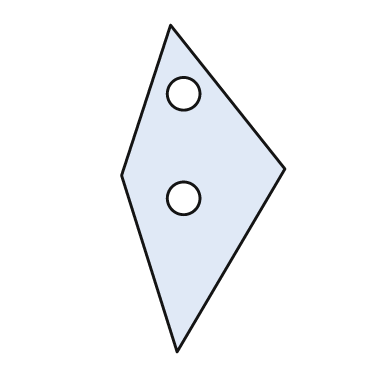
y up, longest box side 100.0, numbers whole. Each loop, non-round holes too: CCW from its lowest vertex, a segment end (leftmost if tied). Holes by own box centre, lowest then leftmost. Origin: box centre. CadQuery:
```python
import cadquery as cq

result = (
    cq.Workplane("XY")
    .moveTo(-8.0, -50.0)
    .lineTo(25.0, 6.0)
    .lineTo(-10.0, 50.0)
    .lineTo(-25.0, 4.0)
    .close()
    .moveTo(-6.0, -3.0)
    .circle(5.0)
    .moveTo(-6.0, 29.0)
    .circle(5.0)
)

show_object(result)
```